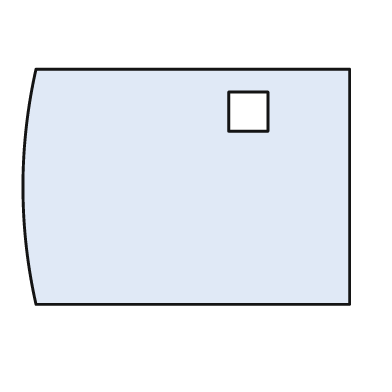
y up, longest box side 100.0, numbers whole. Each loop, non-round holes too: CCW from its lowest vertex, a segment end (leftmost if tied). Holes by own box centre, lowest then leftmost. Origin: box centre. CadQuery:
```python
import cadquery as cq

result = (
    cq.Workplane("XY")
    .moveTo(-46.0, -36.0)
    .lineTo(50.0, -36.0)
    .lineTo(50.0, 36.0)
    .lineTo(-46.0, 36.0)
    .threePointArc((-50.0, 0.0), (-46.0, -36.0))
    .close()
    .moveTo(13.0, 17.0)
    .lineTo(25.0, 17.0)
    .lineTo(25.0, 29.0)
    .lineTo(13.0, 29.0)
    .close()
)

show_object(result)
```